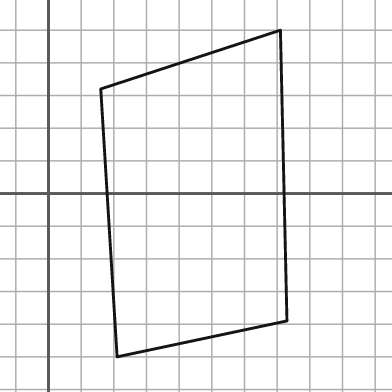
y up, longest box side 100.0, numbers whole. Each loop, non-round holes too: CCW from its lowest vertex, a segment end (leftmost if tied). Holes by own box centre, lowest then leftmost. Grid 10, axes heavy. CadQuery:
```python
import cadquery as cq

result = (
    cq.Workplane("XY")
    .moveTo(21.0, -50.0)
    .lineTo(73.0, -39.0)
    .lineTo(71.0, 50.0)
    .lineTo(16.0, 32.0)
    .close()
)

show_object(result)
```